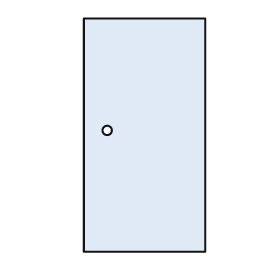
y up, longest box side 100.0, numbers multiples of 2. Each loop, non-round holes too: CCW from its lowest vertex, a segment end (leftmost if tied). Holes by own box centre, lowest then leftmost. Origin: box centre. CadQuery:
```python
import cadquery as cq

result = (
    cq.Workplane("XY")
    .moveTo(-26.0, -50.0)
    .lineTo(26.0, -50.0)
    .lineTo(26.0, 50.0)
    .lineTo(-26.0, 50.0)
    .close()
    .moveTo(-16.0, 2.0)
    .circle(2.0)
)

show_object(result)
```